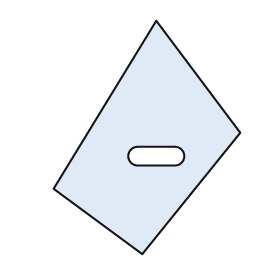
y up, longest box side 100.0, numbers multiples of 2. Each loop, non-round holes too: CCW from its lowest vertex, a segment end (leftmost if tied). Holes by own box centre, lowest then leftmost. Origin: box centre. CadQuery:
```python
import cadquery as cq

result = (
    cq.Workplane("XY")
    .moveTo(-2.0, -50.0)
    .lineTo(40.0, 2.0)
    .lineTo(4.0, 50.0)
    .lineTo(-40.0, -22.0)
    .close()
    .moveTo(-4.0, -12.0)
    .lineTo(12.0, -12.0)
    .threePointArc((16.0, -8.0), (12.0, -4.0))
    .lineTo(-4.0, -4.0)
    .threePointArc((-8.0, -8.0), (-4.0, -12.0))
    .close()
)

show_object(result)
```